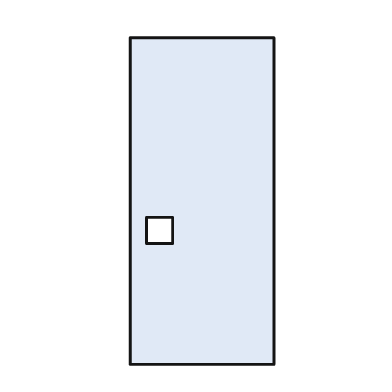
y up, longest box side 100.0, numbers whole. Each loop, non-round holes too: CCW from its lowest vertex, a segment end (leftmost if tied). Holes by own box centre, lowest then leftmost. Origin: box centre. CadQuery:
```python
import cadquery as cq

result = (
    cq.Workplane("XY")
    .moveTo(-22.0, -50.0)
    .lineTo(22.0, -50.0)
    .lineTo(22.0, 50.0)
    .lineTo(-22.0, 50.0)
    .close()
    .moveTo(-17.0, -13.0)
    .lineTo(-9.0, -13.0)
    .lineTo(-9.0, -5.0)
    .lineTo(-17.0, -5.0)
    .close()
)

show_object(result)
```